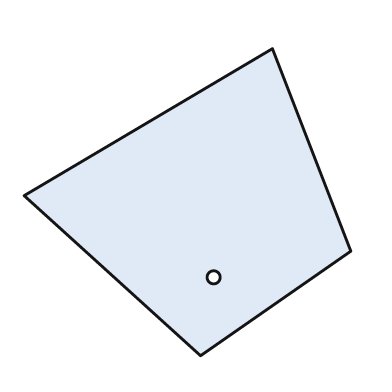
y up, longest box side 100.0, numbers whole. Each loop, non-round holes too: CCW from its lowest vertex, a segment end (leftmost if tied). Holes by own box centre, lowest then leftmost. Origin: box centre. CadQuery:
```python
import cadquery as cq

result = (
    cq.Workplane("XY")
    .moveTo(4.0, -47.0)
    .lineTo(50.0, -15.0)
    .lineTo(26.0, 47.0)
    .lineTo(-50.0, 2.0)
    .close()
    .moveTo(8.0, -23.0)
    .circle(2.0)
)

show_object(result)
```